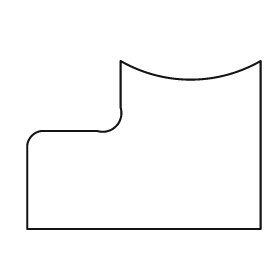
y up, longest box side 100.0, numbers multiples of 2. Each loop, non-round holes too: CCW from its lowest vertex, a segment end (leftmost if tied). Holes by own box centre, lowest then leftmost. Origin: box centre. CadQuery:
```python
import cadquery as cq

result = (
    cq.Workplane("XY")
    .moveTo(-50.0, -36.0)
    .lineTo(50.0, -36.0)
    .lineTo(50.0, 36.0)
    .threePointArc((20.0, 28.0), (-10.0, 36.0))
    .lineTo(-10.0, 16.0)
    .threePointArc((-12.0, 8.0), (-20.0, 6.0))
    .lineTo(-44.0, 6.0)
    .threePointArc((-48.0, 4.0), (-50.0, 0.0))
    .close()
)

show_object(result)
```